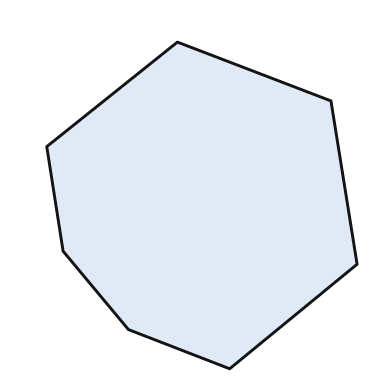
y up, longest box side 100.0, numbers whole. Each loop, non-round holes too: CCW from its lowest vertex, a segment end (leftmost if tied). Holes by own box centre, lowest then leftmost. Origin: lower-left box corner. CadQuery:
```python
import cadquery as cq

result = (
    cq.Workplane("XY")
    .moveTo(56.0, 0.0)
    .lineTo(95.0, 32.0)
    .lineTo(87.0, 82.0)
    .lineTo(40.0, 100.0)
    .lineTo(0.0, 68.0)
    .lineTo(5.0, 36.0)
    .lineTo(25.0, 12.0)
    .close()
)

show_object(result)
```